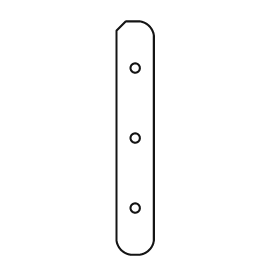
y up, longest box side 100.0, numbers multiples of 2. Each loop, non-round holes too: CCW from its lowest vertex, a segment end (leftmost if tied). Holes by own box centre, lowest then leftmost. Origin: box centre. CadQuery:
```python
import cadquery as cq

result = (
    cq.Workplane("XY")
    .moveTo(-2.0, -50.0)
    .lineTo(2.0, -50.0)
    .threePointArc((6.0, -48.0), (8.0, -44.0))
    .lineTo(8.0, 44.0)
    .threePointArc((6.0, 48.0), (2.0, 50.0))
    .lineTo(-4.0, 50.0)
    .lineTo(-8.0, 46.0)
    .lineTo(-8.0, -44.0)
    .threePointArc((-6.0, -48.0), (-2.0, -50.0))
    .close()
    .moveTo(0.0, -30.0)
    .circle(2.0)
    .moveTo(0.0, 0.0)
    .circle(2.0)
    .moveTo(0.0, 30.0)
    .circle(2.0)
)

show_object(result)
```